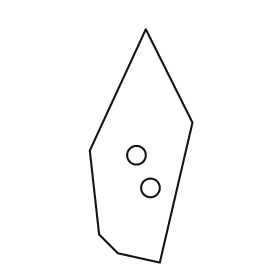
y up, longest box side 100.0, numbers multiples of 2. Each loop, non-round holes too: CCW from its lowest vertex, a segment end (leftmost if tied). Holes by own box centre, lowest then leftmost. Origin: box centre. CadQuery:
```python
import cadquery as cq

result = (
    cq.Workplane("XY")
    .moveTo(8.0, -50.0)
    .lineTo(22.0, 10.0)
    .lineTo(2.0, 50.0)
    .lineTo(-22.0, -2.0)
    .lineTo(-18.0, -38.0)
    .lineTo(-10.0, -46.0)
    .close()
    .moveTo(4.0, -18.0)
    .circle(4.0)
    .moveTo(-2.0, -4.0)
    .circle(4.0)
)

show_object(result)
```